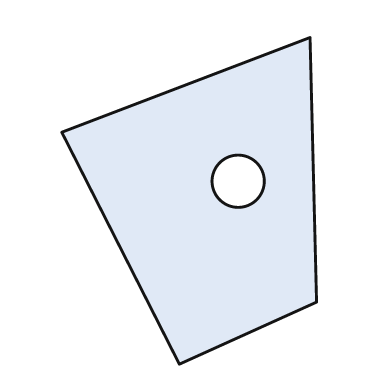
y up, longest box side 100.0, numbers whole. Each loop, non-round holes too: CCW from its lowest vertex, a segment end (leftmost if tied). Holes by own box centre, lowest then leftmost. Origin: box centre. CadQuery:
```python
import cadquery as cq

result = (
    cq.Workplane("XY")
    .moveTo(-3.0, -50.0)
    .lineTo(39.0, -31.0)
    .lineTo(37.0, 50.0)
    .lineTo(-39.0, 21.0)
    .close()
    .moveTo(15.0, 6.0)
    .circle(8.0)
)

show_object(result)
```